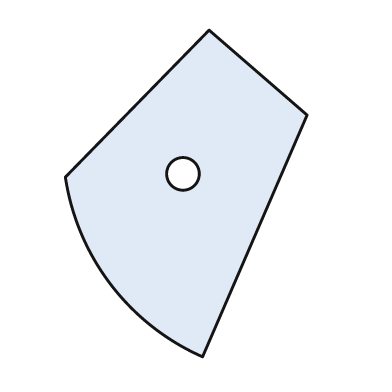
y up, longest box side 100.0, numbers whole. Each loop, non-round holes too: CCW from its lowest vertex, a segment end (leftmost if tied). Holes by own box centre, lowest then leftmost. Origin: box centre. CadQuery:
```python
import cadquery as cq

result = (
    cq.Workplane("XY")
    .moveTo(5.0, -50.0)
    .lineTo(37.0, 24.0)
    .lineTo(7.0, 50.0)
    .lineTo(-37.0, 5.0)
    .threePointArc((-23.0, -28.0), (5.0, -50.0))
    .close()
    .moveTo(-1.0, 6.0)
    .circle(5.0)
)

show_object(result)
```